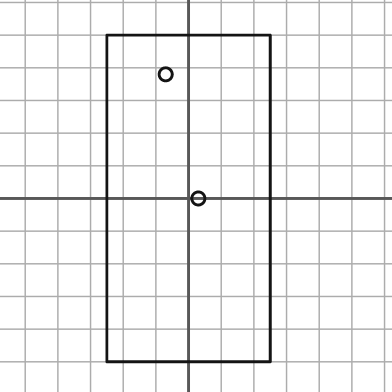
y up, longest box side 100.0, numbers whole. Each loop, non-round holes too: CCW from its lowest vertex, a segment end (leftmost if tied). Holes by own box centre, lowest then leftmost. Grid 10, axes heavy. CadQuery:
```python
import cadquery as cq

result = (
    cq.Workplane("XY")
    .moveTo(-25.0, -50.0)
    .lineTo(25.0, -50.0)
    .lineTo(25.0, 50.0)
    .lineTo(-25.0, 50.0)
    .close()
    .moveTo(3.0, 0.0)
    .circle(2.0)
    .moveTo(-7.0, 38.0)
    .circle(2.0)
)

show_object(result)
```